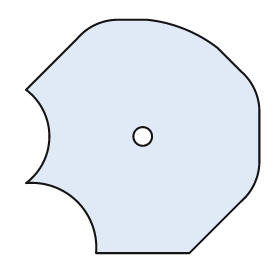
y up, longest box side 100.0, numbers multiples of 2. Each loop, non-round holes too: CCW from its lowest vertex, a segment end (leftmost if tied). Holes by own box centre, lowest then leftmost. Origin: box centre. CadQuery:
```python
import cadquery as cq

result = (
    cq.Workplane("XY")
    .moveTo(-20.0, -50.0)
    .lineTo(20.0, -50.0)
    .lineTo(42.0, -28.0)
    .threePointArc((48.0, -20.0), (50.0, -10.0))
    .lineTo(50.0, 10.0)
    .threePointArc((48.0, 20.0), (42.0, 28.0))
    .lineTo(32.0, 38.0)
    .threePointArc((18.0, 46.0), (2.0, 50.0))
    .lineTo(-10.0, 50.0)
    .threePointArc((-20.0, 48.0), (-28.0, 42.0))
    .lineTo(-50.0, 20.0)
    .threePointArc((-40.0, 0.0), (-50.0, -20.0))
    .threePointArc((-28.0, -28.0), (-20.0, -50.0))
    .close()
    .moveTo(0.0, 0.0)
    .circle(4.0)
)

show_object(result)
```